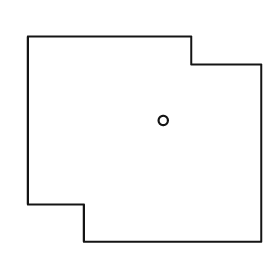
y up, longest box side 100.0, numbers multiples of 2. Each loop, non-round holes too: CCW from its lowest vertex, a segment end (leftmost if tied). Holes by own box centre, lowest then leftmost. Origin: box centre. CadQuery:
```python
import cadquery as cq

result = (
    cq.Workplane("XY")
    .moveTo(-26.0, -44.0)
    .lineTo(50.0, -44.0)
    .lineTo(50.0, 32.0)
    .lineTo(20.0, 32.0)
    .lineTo(20.0, 44.0)
    .lineTo(-50.0, 44.0)
    .lineTo(-50.0, -28.0)
    .lineTo(-26.0, -28.0)
    .close()
    .moveTo(8.0, 8.0)
    .circle(2.0)
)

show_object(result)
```